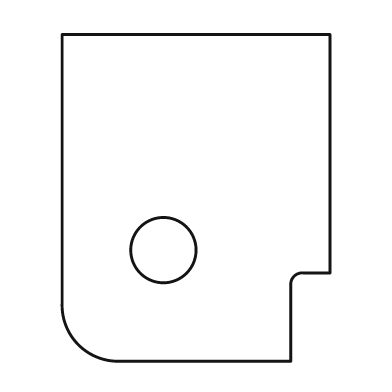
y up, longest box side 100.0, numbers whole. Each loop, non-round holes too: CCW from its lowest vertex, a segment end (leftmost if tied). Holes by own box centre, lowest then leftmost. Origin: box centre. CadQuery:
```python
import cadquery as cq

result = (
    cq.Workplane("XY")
    .moveTo(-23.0, -50.0)
    .lineTo(29.0, -50.0)
    .lineTo(29.0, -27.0)
    .threePointArc((30.0, -24.0), (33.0, -23.0))
    .lineTo(41.0, -23.0)
    .lineTo(41.0, 50.0)
    .lineTo(-41.0, 50.0)
    .lineTo(-41.0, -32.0)
    .threePointArc((-36.0, -45.0), (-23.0, -50.0))
    .close()
    .moveTo(-10.0, -16.0)
    .circle(10.0)
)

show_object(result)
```